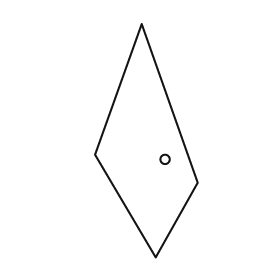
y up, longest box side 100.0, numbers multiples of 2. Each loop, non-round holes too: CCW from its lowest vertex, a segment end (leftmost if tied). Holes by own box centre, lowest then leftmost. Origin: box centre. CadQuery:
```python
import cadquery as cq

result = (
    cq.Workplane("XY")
    .moveTo(4.0, -50.0)
    .lineTo(22.0, -18.0)
    .lineTo(-2.0, 50.0)
    .lineTo(-22.0, -6.0)
    .close()
    .moveTo(8.0, -8.0)
    .circle(2.0)
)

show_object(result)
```